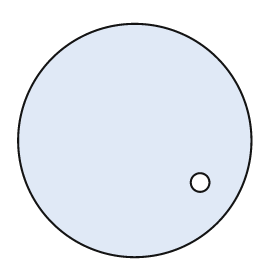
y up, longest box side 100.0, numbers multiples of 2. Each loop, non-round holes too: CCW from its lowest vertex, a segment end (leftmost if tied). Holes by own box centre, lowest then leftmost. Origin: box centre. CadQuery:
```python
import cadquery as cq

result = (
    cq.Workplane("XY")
    .moveTo(0.0, 0.0)
    .circle(50.0)
    .moveTo(28.0, -18.0)
    .circle(4.0)
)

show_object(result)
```